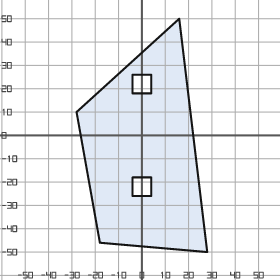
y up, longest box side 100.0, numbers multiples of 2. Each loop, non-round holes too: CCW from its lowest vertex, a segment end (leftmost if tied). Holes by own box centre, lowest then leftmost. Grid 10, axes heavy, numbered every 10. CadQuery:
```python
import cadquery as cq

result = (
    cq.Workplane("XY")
    .moveTo(28.0, -50.0)
    .lineTo(16.0, 50.0)
    .lineTo(-28.0, 10.0)
    .lineTo(-18.0, -46.0)
    .close()
    .moveTo(-4.0, -26.0)
    .lineTo(4.0, -26.0)
    .lineTo(4.0, -18.0)
    .lineTo(-4.0, -18.0)
    .close()
    .moveTo(-4.0, 18.0)
    .lineTo(4.0, 18.0)
    .lineTo(4.0, 26.0)
    .lineTo(-4.0, 26.0)
    .close()
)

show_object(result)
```